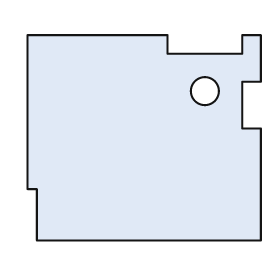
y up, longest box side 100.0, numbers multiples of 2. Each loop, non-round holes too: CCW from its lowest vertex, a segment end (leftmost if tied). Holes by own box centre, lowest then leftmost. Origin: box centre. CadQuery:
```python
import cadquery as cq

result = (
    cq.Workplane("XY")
    .moveTo(-46.0, -44.0)
    .lineTo(50.0, -44.0)
    .lineTo(50.0, 4.0)
    .lineTo(42.0, 4.0)
    .lineTo(42.0, 24.0)
    .lineTo(50.0, 24.0)
    .lineTo(50.0, 44.0)
    .lineTo(42.0, 44.0)
    .lineTo(42.0, 36.0)
    .lineTo(10.0, 36.0)
    .lineTo(10.0, 44.0)
    .lineTo(-50.0, 44.0)
    .lineTo(-50.0, -22.0)
    .lineTo(-46.0, -22.0)
    .close()
    .moveTo(26.0, 20.0)
    .circle(6.0)
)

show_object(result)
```